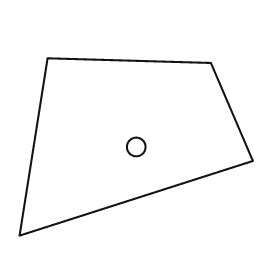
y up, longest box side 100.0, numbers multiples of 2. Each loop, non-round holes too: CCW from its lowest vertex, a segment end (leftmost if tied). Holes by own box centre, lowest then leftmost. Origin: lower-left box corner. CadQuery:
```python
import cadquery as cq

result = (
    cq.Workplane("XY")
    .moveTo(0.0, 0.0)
    .lineTo(100.0, 32.0)
    .lineTo(82.0, 74.0)
    .lineTo(12.0, 76.0)
    .close()
    .moveTo(50.0, 38.0)
    .circle(4.0)
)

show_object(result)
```